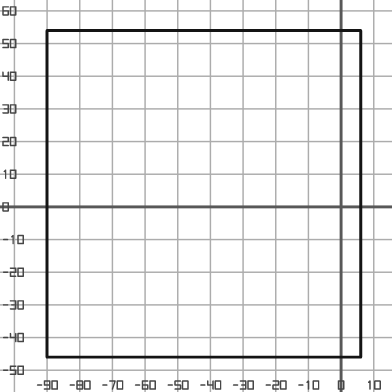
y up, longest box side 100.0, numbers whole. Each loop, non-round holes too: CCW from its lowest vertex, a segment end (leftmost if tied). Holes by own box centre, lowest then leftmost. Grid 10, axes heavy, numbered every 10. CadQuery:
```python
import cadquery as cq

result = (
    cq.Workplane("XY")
    .moveTo(-90.0, -46.0)
    .lineTo(6.0, -46.0)
    .lineTo(6.0, 54.0)
    .lineTo(-90.0, 54.0)
    .close()
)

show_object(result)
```